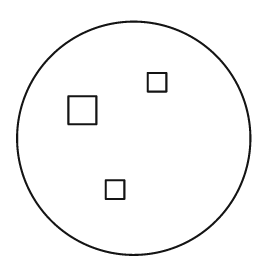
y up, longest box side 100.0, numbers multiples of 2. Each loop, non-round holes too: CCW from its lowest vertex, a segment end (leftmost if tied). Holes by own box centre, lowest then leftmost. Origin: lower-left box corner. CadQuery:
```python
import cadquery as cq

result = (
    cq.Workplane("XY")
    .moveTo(50.0, 50.0)
    .circle(50.0)
    .moveTo(38.0, 24.0)
    .lineTo(46.0, 24.0)
    .lineTo(46.0, 32.0)
    .lineTo(38.0, 32.0)
    .close()
    .moveTo(22.0, 56.0)
    .lineTo(34.0, 56.0)
    .lineTo(34.0, 68.0)
    .lineTo(22.0, 68.0)
    .close()
    .moveTo(56.0, 70.0)
    .lineTo(64.0, 70.0)
    .lineTo(64.0, 78.0)
    .lineTo(56.0, 78.0)
    .close()
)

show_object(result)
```